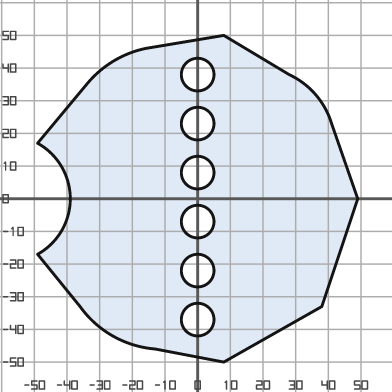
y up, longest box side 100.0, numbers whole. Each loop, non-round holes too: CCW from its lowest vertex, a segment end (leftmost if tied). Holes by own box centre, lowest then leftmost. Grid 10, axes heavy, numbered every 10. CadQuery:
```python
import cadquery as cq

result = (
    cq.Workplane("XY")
    .moveTo(8.0, -50.0)
    .lineTo(38.0, -33.0)
    .lineTo(49.0, 0.0)
    .lineTo(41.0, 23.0)
    .threePointArc((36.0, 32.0), (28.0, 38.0))
    .lineTo(8.0, 50.0)
    .lineTo(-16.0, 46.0)
    .threePointArc((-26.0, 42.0), (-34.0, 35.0))
    .lineTo(-49.0, 17.0)
    .threePointArc((-39.0, 0.0), (-49.0, -17.0))
    .lineTo(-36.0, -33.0)
    .threePointArc((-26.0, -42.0), (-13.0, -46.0))
    .close()
    .moveTo(0.0, -37.0)
    .circle(5.0)
    .moveTo(0.0, -22.0)
    .circle(5.0)
    .moveTo(0.0, -7.0)
    .circle(5.0)
    .moveTo(0.0, 8.0)
    .circle(5.0)
    .moveTo(0.0, 23.0)
    .circle(5.0)
    .moveTo(0.0, 38.0)
    .circle(5.0)
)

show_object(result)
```